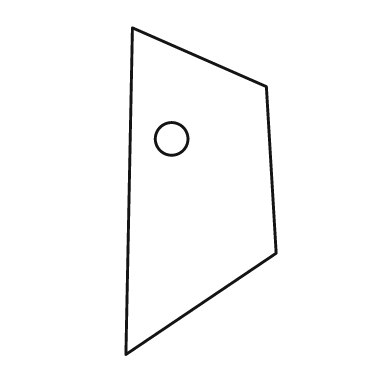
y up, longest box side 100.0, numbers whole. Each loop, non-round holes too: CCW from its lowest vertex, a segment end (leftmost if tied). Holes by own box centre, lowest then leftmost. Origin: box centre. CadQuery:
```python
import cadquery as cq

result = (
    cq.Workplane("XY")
    .moveTo(-23.0, -50.0)
    .lineTo(23.0, -19.0)
    .lineTo(20.0, 32.0)
    .lineTo(-21.0, 50.0)
    .close()
    .moveTo(-9.0, 16.0)
    .circle(5.0)
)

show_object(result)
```